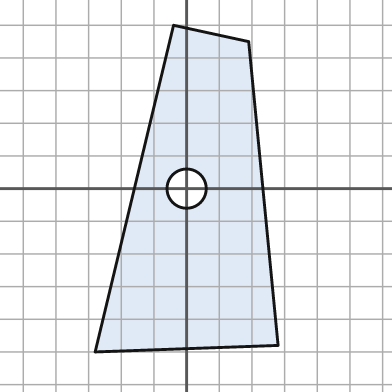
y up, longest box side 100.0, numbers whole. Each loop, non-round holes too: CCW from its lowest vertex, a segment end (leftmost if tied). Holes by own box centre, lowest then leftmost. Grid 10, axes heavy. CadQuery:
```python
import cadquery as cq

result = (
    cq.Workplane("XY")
    .moveTo(-28.0, -50.0)
    .lineTo(28.0, -48.0)
    .lineTo(19.0, 45.0)
    .lineTo(-4.0, 50.0)
    .close()
    .moveTo(0.0, 0.0)
    .circle(6.0)
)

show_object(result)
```